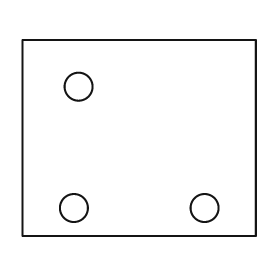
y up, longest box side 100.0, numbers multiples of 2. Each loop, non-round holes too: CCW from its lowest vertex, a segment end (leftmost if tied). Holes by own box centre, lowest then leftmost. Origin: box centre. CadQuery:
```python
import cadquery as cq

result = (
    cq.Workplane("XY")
    .moveTo(-50.0, -42.0)
    .lineTo(50.0, -42.0)
    .lineTo(50.0, 42.0)
    .lineTo(-50.0, 42.0)
    .close()
    .moveTo(-28.0, -30.0)
    .circle(6.0)
    .moveTo(28.0, -30.0)
    .circle(6.0)
    .moveTo(-26.0, 22.0)
    .circle(6.0)
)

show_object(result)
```